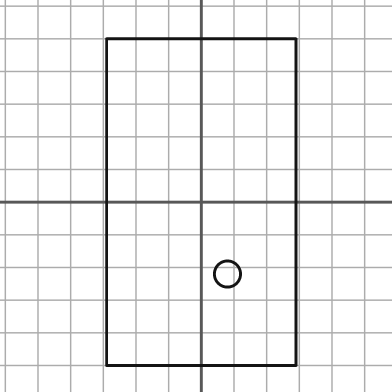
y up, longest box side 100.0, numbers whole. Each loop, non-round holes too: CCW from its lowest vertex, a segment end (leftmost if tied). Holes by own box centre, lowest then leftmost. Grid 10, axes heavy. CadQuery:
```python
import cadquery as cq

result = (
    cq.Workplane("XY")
    .moveTo(-29.0, -50.0)
    .lineTo(29.0, -50.0)
    .lineTo(29.0, 50.0)
    .lineTo(-29.0, 50.0)
    .close()
    .moveTo(8.0, -22.0)
    .circle(4.0)
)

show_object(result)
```